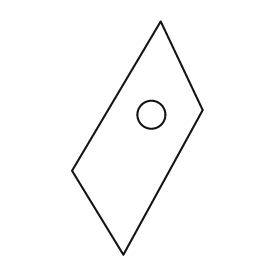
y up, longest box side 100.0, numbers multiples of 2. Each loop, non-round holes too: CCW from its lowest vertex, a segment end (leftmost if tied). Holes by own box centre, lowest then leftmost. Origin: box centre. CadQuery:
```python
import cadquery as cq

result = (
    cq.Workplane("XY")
    .moveTo(-6.0, -50.0)
    .lineTo(28.0, 12.0)
    .lineTo(10.0, 50.0)
    .lineTo(-28.0, -14.0)
    .close()
    .moveTo(6.0, 10.0)
    .circle(6.0)
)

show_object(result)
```